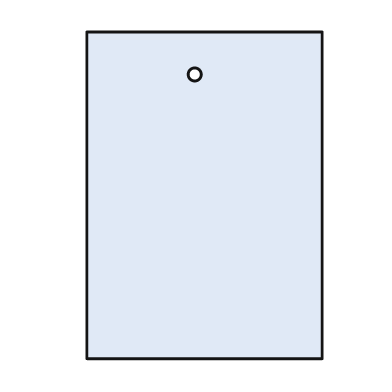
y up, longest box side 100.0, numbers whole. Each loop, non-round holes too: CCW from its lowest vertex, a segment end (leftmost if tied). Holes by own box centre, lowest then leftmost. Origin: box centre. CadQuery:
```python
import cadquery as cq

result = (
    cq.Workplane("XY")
    .moveTo(-36.0, -50.0)
    .lineTo(36.0, -50.0)
    .lineTo(36.0, 50.0)
    .lineTo(-36.0, 50.0)
    .close()
    .moveTo(-3.0, 37.0)
    .circle(2.0)
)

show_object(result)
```